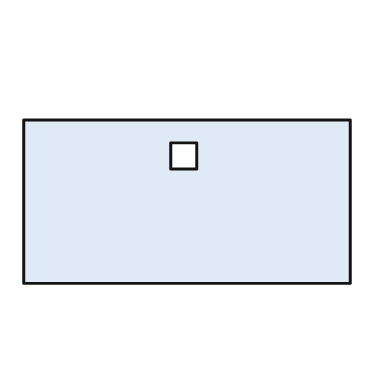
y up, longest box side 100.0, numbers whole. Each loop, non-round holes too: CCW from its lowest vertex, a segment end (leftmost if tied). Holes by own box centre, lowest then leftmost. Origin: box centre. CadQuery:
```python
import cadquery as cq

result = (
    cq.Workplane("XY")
    .moveTo(-50.0, -25.0)
    .lineTo(50.0, -25.0)
    .lineTo(50.0, 25.0)
    .lineTo(-50.0, 25.0)
    .close()
    .moveTo(-5.0, 10.0)
    .lineTo(3.0, 10.0)
    .lineTo(3.0, 18.0)
    .lineTo(-5.0, 18.0)
    .close()
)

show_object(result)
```